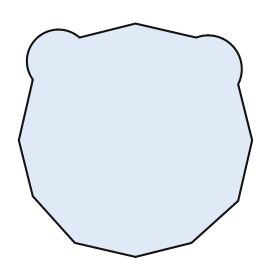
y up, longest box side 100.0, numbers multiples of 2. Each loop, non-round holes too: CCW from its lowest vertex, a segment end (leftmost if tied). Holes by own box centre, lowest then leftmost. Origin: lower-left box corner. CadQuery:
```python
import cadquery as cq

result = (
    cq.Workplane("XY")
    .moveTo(50.0, 0.0)
    .lineTo(74.0, 6.0)
    .lineTo(94.0, 24.0)
    .lineTo(100.0, 50.0)
    .lineTo(94.0, 74.0)
    .threePointArc((92.0, 90.0), (76.0, 94.0))
    .lineTo(50.0, 100.0)
    .lineTo(26.0, 94.0)
    .threePointArc((8.0, 94.0), (6.0, 76.0))
    .lineTo(0.0, 50.0)
    .lineTo(6.0, 26.0)
    .lineTo(24.0, 6.0)
    .close()
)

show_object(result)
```